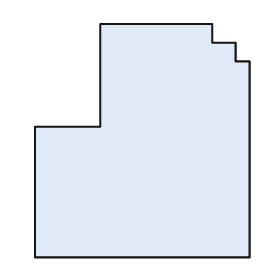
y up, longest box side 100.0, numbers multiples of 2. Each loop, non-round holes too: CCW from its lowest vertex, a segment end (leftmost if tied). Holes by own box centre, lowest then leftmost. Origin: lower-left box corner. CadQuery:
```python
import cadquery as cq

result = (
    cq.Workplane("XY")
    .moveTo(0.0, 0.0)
    .lineTo(92.0, 0.0)
    .lineTo(92.0, 84.0)
    .lineTo(86.0, 84.0)
    .lineTo(86.0, 92.0)
    .lineTo(76.0, 92.0)
    .lineTo(76.0, 100.0)
    .lineTo(28.0, 100.0)
    .lineTo(28.0, 56.0)
    .lineTo(0.0, 56.0)
    .close()
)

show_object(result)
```